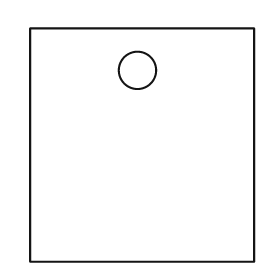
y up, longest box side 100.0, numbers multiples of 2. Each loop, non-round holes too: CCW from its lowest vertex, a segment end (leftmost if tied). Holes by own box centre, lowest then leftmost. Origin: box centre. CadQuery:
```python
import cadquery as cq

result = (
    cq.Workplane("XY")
    .moveTo(-48.0, -50.0)
    .lineTo(48.0, -50.0)
    .lineTo(48.0, 50.0)
    .lineTo(-48.0, 50.0)
    .close()
    .moveTo(-2.0, 32.0)
    .circle(8.0)
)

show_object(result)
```